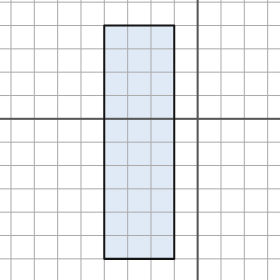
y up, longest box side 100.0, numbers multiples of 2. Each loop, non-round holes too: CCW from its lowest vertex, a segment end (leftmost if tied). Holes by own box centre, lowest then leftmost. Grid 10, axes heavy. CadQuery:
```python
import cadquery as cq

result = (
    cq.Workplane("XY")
    .moveTo(-40.0, -60.0)
    .lineTo(-10.0, -60.0)
    .lineTo(-10.0, 40.0)
    .lineTo(-40.0, 40.0)
    .close()
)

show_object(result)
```